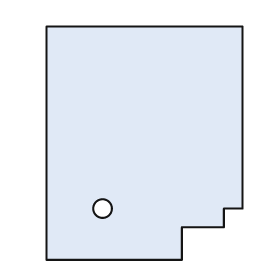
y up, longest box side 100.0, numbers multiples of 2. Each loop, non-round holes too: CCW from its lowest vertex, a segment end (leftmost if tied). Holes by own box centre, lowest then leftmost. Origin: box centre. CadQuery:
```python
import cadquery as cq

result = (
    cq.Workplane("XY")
    .moveTo(-42.0, -50.0)
    .lineTo(16.0, -50.0)
    .lineTo(16.0, -36.0)
    .lineTo(34.0, -36.0)
    .lineTo(34.0, -28.0)
    .lineTo(42.0, -28.0)
    .lineTo(42.0, 50.0)
    .lineTo(-42.0, 50.0)
    .close()
    .moveTo(-18.0, -28.0)
    .circle(4.0)
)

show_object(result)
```